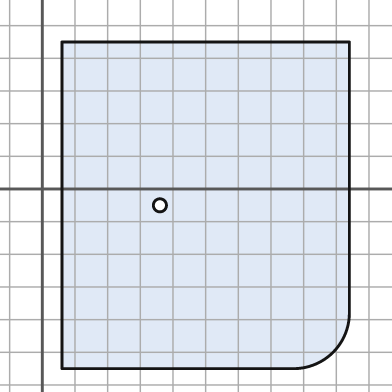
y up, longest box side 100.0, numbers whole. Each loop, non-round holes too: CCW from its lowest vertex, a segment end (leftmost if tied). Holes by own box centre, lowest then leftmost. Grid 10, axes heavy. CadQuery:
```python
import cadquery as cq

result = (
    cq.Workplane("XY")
    .moveTo(6.0, -55.0)
    .lineTo(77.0, -55.0)
    .threePointArc((89.0, -50.0), (94.0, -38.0))
    .lineTo(94.0, 45.0)
    .lineTo(6.0, 45.0)
    .close()
    .moveTo(36.0, -5.0)
    .circle(2.0)
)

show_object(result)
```